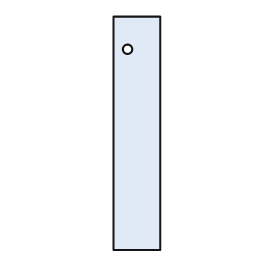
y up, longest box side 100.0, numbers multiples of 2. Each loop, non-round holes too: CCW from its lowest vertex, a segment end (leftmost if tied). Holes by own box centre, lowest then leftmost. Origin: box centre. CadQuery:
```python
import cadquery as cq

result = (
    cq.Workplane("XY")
    .moveTo(-10.0, -50.0)
    .lineTo(10.0, -50.0)
    .lineTo(10.0, 50.0)
    .lineTo(-10.0, 50.0)
    .close()
    .moveTo(-4.0, 36.0)
    .circle(2.0)
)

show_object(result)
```